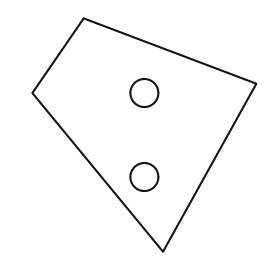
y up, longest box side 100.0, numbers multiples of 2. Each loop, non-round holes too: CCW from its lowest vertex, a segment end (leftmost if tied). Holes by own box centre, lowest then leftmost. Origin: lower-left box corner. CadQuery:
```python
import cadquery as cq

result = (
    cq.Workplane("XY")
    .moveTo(56.0, 0.0)
    .lineTo(96.0, 72.0)
    .lineTo(22.0, 100.0)
    .lineTo(0.0, 68.0)
    .close()
    .moveTo(48.0, 32.0)
    .circle(6.0)
    .moveTo(48.0, 68.0)
    .circle(6.0)
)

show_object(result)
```